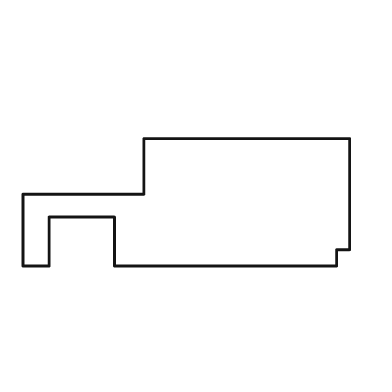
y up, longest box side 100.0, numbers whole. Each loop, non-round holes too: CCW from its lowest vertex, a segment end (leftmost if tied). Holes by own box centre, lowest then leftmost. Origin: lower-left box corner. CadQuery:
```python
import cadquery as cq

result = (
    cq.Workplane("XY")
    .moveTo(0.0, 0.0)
    .lineTo(8.0, 0.0)
    .lineTo(8.0, 15.0)
    .lineTo(28.0, 15.0)
    .lineTo(28.0, 0.0)
    .lineTo(96.0, 0.0)
    .lineTo(96.0, 5.0)
    .lineTo(100.0, 5.0)
    .lineTo(100.0, 39.0)
    .lineTo(37.0, 39.0)
    .lineTo(37.0, 22.0)
    .lineTo(0.0, 22.0)
    .close()
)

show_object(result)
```